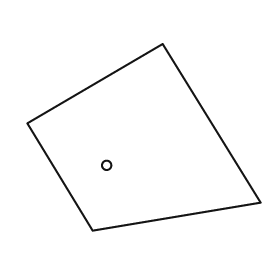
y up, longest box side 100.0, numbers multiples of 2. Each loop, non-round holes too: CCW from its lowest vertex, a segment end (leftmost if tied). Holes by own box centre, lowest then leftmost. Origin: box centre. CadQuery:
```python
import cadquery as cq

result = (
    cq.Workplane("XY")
    .moveTo(-22.0, -40.0)
    .lineTo(50.0, -28.0)
    .lineTo(8.0, 40.0)
    .lineTo(-50.0, 6.0)
    .close()
    .moveTo(-16.0, -12.0)
    .circle(2.0)
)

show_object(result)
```